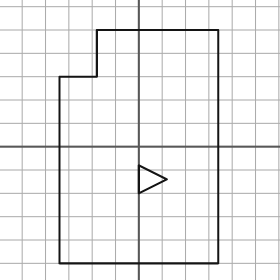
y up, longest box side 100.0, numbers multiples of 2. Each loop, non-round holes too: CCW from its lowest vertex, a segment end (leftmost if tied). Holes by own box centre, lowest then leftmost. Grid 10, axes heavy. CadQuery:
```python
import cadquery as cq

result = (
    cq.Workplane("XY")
    .moveTo(-34.0, -50.0)
    .lineTo(34.0, -50.0)
    .lineTo(34.0, 50.0)
    .lineTo(-18.0, 50.0)
    .lineTo(-18.0, 30.0)
    .lineTo(-34.0, 30.0)
    .close()
    .moveTo(0.0, -20.0)
    .lineTo(12.0, -14.0)
    .lineTo(0.0, -8.0)
    .close()
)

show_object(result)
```